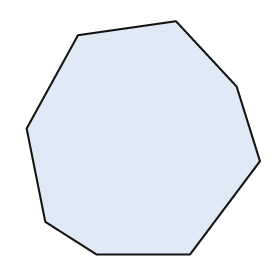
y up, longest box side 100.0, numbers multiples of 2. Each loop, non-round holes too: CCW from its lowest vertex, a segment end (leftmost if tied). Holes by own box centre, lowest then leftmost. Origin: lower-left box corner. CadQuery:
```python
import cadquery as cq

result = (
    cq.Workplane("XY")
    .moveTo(30.0, 0.0)
    .lineTo(70.0, 0.0)
    .lineTo(100.0, 40.0)
    .lineTo(90.0, 72.0)
    .lineTo(64.0, 100.0)
    .lineTo(22.0, 94.0)
    .lineTo(0.0, 54.0)
    .lineTo(8.0, 14.0)
    .close()
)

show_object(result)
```